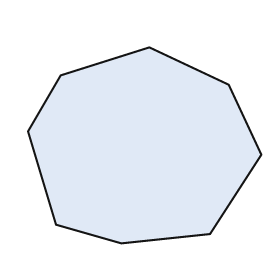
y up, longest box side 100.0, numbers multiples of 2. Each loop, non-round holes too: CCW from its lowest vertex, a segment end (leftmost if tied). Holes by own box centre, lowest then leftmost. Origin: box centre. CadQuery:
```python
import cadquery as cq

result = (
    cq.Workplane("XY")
    .moveTo(-10.0, -42.0)
    .lineTo(28.0, -38.0)
    .lineTo(50.0, -4.0)
    .lineTo(36.0, 26.0)
    .lineTo(2.0, 42.0)
    .lineTo(-36.0, 30.0)
    .lineTo(-50.0, 6.0)
    .lineTo(-38.0, -34.0)
    .close()
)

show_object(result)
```